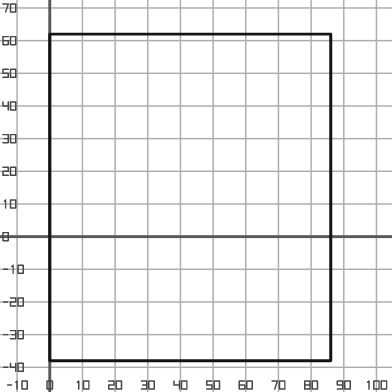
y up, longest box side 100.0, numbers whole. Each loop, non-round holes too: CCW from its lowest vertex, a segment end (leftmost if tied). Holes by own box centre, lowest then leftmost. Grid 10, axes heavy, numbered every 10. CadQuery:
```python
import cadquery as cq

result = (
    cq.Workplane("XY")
    .moveTo(0.0, -38.0)
    .lineTo(86.0, -38.0)
    .lineTo(86.0, 62.0)
    .lineTo(0.0, 62.0)
    .close()
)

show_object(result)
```